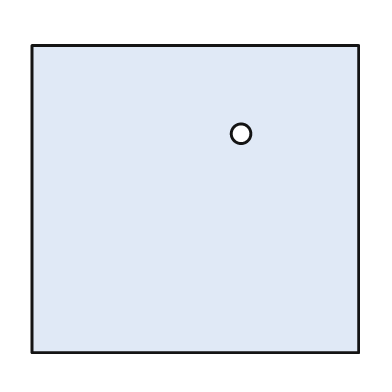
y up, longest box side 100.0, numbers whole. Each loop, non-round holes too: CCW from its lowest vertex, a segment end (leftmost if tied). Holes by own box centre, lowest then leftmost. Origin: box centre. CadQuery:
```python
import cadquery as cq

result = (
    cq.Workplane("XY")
    .moveTo(-50.0, -47.0)
    .lineTo(50.0, -47.0)
    .lineTo(50.0, 47.0)
    .lineTo(-50.0, 47.0)
    .close()
    .moveTo(14.0, 20.0)
    .circle(3.0)
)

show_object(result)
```